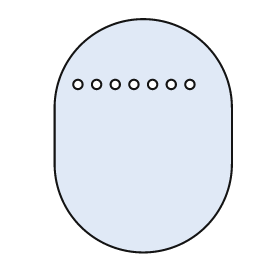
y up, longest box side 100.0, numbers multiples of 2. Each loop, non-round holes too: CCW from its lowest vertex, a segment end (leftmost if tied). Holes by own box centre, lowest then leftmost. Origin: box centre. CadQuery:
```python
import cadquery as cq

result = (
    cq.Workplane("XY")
    .moveTo(-38.0, -12.0)
    .threePointArc((0.0, -50.0), (38.0, -12.0))
    .lineTo(38.0, 12.0)
    .threePointArc((0.0, 50.0), (-38.0, 12.0))
    .close()
    .moveTo(-28.0, 22.0)
    .circle(2.0)
    .moveTo(-20.0, 22.0)
    .circle(2.0)
    .moveTo(-12.0, 22.0)
    .circle(2.0)
    .moveTo(-4.0, 22.0)
    .circle(2.0)
    .moveTo(4.0, 22.0)
    .circle(2.0)
    .moveTo(12.0, 22.0)
    .circle(2.0)
    .moveTo(20.0, 22.0)
    .circle(2.0)
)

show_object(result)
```